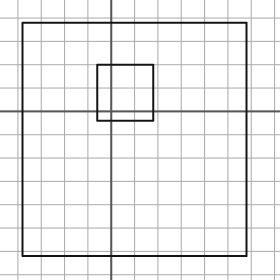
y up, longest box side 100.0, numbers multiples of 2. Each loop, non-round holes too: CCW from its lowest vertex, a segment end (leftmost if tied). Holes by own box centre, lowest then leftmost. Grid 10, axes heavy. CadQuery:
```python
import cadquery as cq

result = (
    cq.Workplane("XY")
    .moveTo(-38.0, -62.0)
    .lineTo(58.0, -62.0)
    .lineTo(58.0, 38.0)
    .lineTo(-38.0, 38.0)
    .close()
    .moveTo(-6.0, -4.0)
    .lineTo(18.0, -4.0)
    .lineTo(18.0, 20.0)
    .lineTo(-6.0, 20.0)
    .close()
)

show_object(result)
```